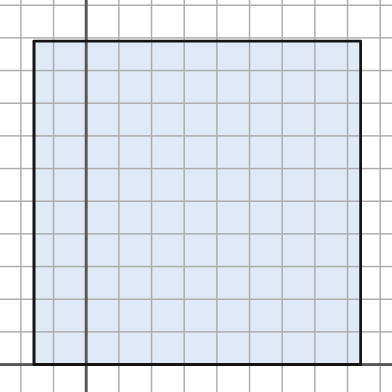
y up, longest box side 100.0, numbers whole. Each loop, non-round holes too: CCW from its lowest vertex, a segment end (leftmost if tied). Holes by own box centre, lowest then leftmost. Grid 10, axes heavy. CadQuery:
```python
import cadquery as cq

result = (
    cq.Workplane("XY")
    .moveTo(-16.0, 0.0)
    .lineTo(84.0, 0.0)
    .lineTo(84.0, 99.0)
    .lineTo(-16.0, 99.0)
    .close()
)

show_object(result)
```